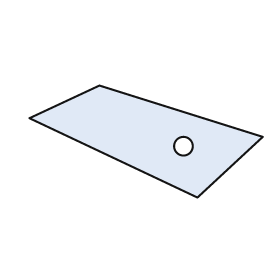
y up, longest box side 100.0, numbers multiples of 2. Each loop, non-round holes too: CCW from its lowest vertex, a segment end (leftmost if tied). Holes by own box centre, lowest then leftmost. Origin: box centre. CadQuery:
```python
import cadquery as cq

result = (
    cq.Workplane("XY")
    .moveTo(22.0, -24.0)
    .lineTo(50.0, 2.0)
    .lineTo(-20.0, 24.0)
    .lineTo(-50.0, 10.0)
    .close()
    .moveTo(16.0, -2.0)
    .circle(4.0)
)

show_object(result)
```